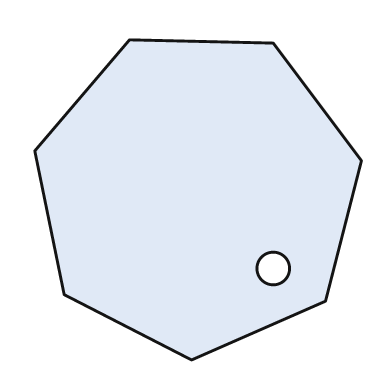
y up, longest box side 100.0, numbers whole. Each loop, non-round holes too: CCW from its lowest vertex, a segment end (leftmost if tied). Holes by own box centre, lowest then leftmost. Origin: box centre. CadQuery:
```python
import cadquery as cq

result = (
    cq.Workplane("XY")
    .moveTo(-2.0, -49.0)
    .lineTo(39.0, -31.0)
    .lineTo(50.0, 12.0)
    .lineTo(23.0, 48.0)
    .lineTo(-21.0, 49.0)
    .lineTo(-50.0, 15.0)
    .lineTo(-41.0, -29.0)
    .close()
    .moveTo(23.0, -21.0)
    .circle(5.0)
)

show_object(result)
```